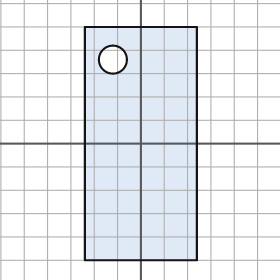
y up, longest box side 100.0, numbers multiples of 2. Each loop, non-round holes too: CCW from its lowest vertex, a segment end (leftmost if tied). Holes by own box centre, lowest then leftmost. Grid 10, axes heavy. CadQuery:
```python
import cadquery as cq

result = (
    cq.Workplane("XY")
    .moveTo(-24.0, -50.0)
    .lineTo(24.0, -50.0)
    .lineTo(24.0, 50.0)
    .lineTo(-24.0, 50.0)
    .close()
    .moveTo(-12.0, 36.0)
    .circle(6.0)
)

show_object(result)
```